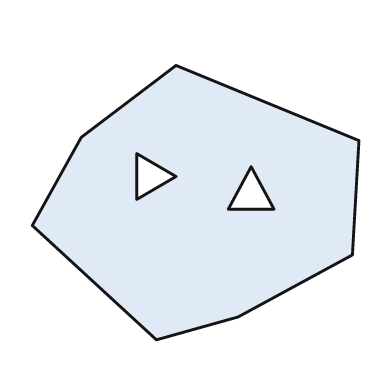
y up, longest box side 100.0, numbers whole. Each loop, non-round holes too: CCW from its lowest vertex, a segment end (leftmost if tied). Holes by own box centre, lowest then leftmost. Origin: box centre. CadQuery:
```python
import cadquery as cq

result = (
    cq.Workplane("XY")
    .moveTo(-12.0, -42.0)
    .lineTo(13.0, -35.0)
    .lineTo(48.0, -16.0)
    .lineTo(50.0, 19.0)
    .lineTo(-6.0, 42.0)
    .lineTo(-35.0, 20.0)
    .lineTo(-50.0, -7.0)
    .close()
    .moveTo(10.0, -2.0)
    .lineTo(24.0, -2.0)
    .lineTo(17.0, 11.0)
    .close()
    .moveTo(-18.0, 1.0)
    .lineTo(-6.0, 8.0)
    .lineTo(-18.0, 15.0)
    .close()
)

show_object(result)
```